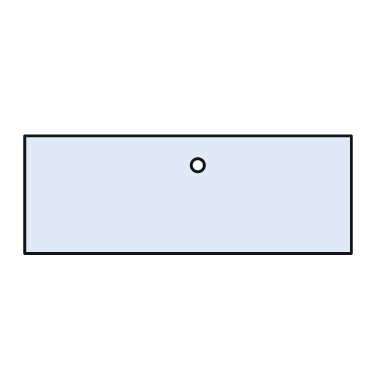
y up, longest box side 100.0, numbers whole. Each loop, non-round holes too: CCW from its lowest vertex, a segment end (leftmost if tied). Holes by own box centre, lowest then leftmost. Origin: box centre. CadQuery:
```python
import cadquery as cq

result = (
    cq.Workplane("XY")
    .moveTo(-50.0, -18.0)
    .lineTo(50.0, -18.0)
    .lineTo(50.0, 18.0)
    .lineTo(-50.0, 18.0)
    .close()
    .moveTo(3.0, 9.0)
    .circle(2.0)
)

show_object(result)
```